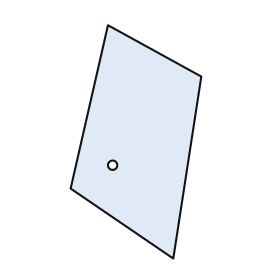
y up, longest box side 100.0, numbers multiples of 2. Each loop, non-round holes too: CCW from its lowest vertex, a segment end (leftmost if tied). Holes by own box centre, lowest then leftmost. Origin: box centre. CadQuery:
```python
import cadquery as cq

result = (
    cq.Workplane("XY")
    .moveTo(16.0, -50.0)
    .lineTo(28.0, 28.0)
    .lineTo(-12.0, 50.0)
    .lineTo(-28.0, -20.0)
    .close()
    .moveTo(-10.0, -10.0)
    .circle(2.0)
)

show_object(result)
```